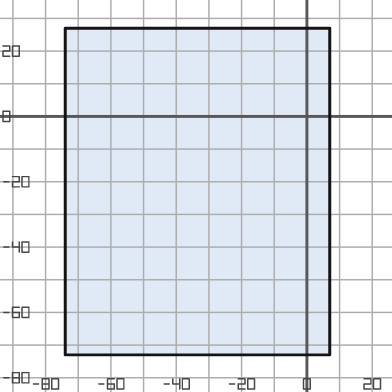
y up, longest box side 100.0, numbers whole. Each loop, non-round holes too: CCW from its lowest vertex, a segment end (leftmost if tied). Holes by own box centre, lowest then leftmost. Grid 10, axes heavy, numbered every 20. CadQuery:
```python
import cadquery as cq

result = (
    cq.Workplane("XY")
    .moveTo(-74.0, -73.0)
    .lineTo(7.0, -73.0)
    .lineTo(7.0, 27.0)
    .lineTo(-74.0, 27.0)
    .close()
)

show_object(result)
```